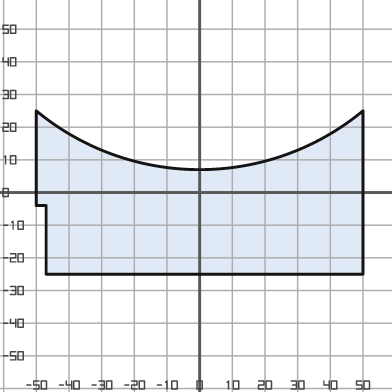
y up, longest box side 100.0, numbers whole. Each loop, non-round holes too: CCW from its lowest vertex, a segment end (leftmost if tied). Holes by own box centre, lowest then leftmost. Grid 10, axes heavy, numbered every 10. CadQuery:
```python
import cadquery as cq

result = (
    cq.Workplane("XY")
    .moveTo(-47.0, -25.0)
    .lineTo(50.0, -25.0)
    .lineTo(50.0, 25.0)
    .threePointArc((0.0, 7.0), (-50.0, 25.0))
    .lineTo(-50.0, -4.0)
    .lineTo(-47.0, -4.0)
    .close()
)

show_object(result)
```